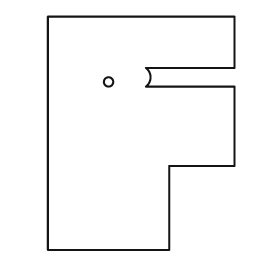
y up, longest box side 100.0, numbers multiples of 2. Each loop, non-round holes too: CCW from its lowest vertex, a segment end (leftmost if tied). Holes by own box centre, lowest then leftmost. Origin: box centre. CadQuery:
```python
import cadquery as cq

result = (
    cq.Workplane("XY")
    .moveTo(-40.0, -50.0)
    .lineTo(12.0, -50.0)
    .lineTo(12.0, -14.0)
    .lineTo(40.0, -14.0)
    .lineTo(40.0, 20.0)
    .lineTo(2.0, 20.0)
    .threePointArc((4.0, 24.0), (2.0, 28.0))
    .lineTo(40.0, 28.0)
    .lineTo(40.0, 50.0)
    .lineTo(-40.0, 50.0)
    .close()
    .moveTo(-14.0, 22.0)
    .circle(2.0)
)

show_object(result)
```